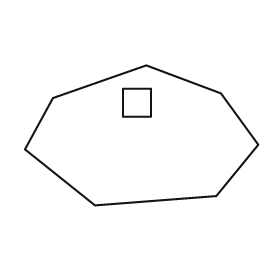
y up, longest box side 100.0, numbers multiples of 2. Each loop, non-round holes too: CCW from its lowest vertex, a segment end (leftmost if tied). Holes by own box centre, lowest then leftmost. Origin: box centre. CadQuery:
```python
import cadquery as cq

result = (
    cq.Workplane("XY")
    .moveTo(-20.0, -30.0)
    .lineTo(32.0, -26.0)
    .lineTo(50.0, -4.0)
    .lineTo(34.0, 18.0)
    .lineTo(2.0, 30.0)
    .lineTo(-38.0, 16.0)
    .lineTo(-50.0, -6.0)
    .close()
    .moveTo(-8.0, 8.0)
    .lineTo(4.0, 8.0)
    .lineTo(4.0, 20.0)
    .lineTo(-8.0, 20.0)
    .close()
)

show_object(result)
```